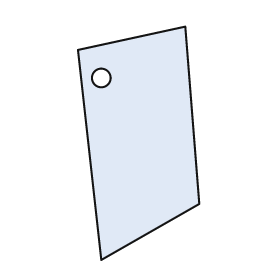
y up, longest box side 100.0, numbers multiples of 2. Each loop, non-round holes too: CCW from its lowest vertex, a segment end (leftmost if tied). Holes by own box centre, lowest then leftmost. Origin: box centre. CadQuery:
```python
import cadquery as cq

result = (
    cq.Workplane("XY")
    .moveTo(-16.0, -50.0)
    .lineTo(26.0, -26.0)
    .lineTo(20.0, 50.0)
    .lineTo(-26.0, 40.0)
    .close()
    .moveTo(-16.0, 28.0)
    .circle(4.0)
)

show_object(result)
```